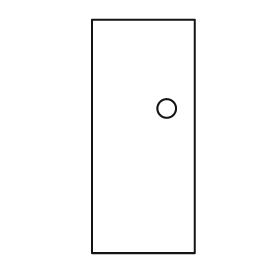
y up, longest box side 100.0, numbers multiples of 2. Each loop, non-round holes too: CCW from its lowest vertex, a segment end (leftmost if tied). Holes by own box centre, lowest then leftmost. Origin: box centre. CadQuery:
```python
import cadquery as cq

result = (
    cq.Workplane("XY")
    .moveTo(-22.0, -50.0)
    .lineTo(22.0, -50.0)
    .lineTo(22.0, 50.0)
    .lineTo(-22.0, 50.0)
    .close()
    .moveTo(10.0, 12.0)
    .circle(4.0)
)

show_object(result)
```